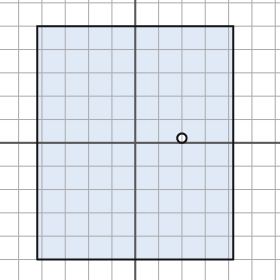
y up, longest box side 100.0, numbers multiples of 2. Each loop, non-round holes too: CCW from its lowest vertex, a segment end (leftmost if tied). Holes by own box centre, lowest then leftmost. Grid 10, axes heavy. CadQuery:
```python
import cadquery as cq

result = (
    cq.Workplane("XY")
    .moveTo(-42.0, -50.0)
    .lineTo(42.0, -50.0)
    .lineTo(42.0, 50.0)
    .lineTo(-42.0, 50.0)
    .close()
    .moveTo(20.0, 2.0)
    .circle(2.0)
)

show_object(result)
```